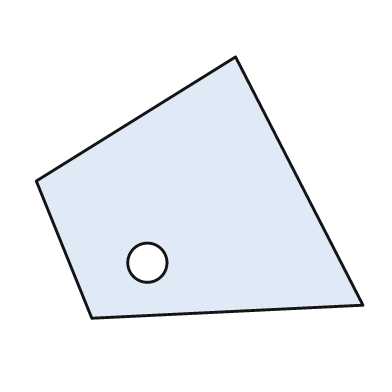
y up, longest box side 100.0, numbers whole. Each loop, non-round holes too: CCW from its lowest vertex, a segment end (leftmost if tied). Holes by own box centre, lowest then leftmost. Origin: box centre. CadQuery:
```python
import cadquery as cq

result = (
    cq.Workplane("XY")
    .moveTo(-33.0, -40.0)
    .lineTo(50.0, -36.0)
    .lineTo(11.0, 40.0)
    .lineTo(-50.0, 2.0)
    .close()
    .moveTo(-16.0, -23.0)
    .circle(6.0)
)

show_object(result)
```